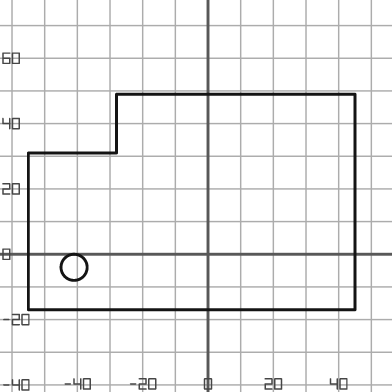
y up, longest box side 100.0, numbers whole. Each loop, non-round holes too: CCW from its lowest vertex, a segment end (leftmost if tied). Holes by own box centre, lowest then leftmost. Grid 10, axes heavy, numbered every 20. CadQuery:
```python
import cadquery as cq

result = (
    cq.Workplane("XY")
    .moveTo(-55.0, -17.0)
    .lineTo(45.0, -17.0)
    .lineTo(45.0, 49.0)
    .lineTo(-28.0, 49.0)
    .lineTo(-28.0, 31.0)
    .lineTo(-55.0, 31.0)
    .close()
    .moveTo(-41.0, -4.0)
    .circle(4.0)
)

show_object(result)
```